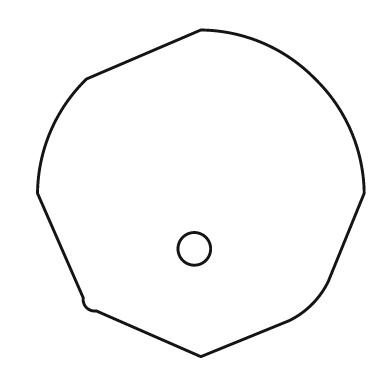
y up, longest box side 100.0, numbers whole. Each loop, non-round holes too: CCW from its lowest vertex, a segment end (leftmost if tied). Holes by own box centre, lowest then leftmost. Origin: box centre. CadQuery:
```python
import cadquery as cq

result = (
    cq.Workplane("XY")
    .moveTo(0.0, -50.0)
    .lineTo(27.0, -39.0)
    .threePointArc((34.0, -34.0), (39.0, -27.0))
    .lineTo(50.0, 0.0)
    .threePointArc((46.0, 19.0), (35.0, 35.0))
    .threePointArc((19.0, 46.0), (0.0, 50.0))
    .lineTo(-35.0, 35.0)
    .threePointArc((-46.0, 19.0), (-50.0, 0.0))
    .lineTo(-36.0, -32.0)
    .threePointArc((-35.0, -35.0), (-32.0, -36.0))
    .close()
    .moveTo(-2.0, -17.0)
    .circle(5.0)
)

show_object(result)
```